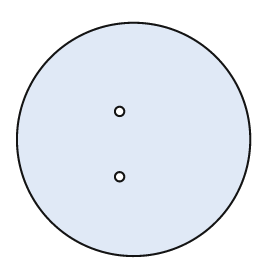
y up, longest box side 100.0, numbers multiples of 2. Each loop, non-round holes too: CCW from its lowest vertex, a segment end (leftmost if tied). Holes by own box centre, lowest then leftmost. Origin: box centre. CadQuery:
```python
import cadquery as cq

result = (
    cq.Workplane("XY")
    .moveTo(0.0, 0.0)
    .circle(50.0)
    .moveTo(-6.0, -16.0)
    .circle(2.0)
    .moveTo(-6.0, 12.0)
    .circle(2.0)
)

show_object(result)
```